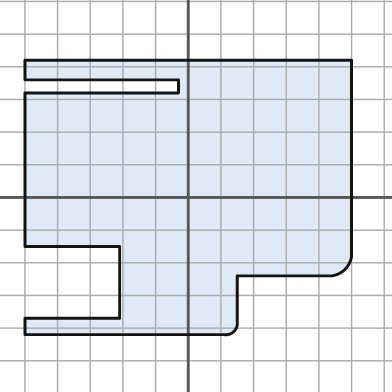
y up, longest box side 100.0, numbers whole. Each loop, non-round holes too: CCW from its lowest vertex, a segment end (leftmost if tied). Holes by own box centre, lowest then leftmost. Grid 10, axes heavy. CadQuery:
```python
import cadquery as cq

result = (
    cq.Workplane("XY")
    .moveTo(-50.0, -42.0)
    .lineTo(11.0, -42.0)
    .threePointArc((14.0, -41.0), (15.0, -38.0))
    .lineTo(15.0, -24.0)
    .lineTo(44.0, -24.0)
    .threePointArc((48.0, -22.0), (50.0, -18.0))
    .lineTo(50.0, 42.0)
    .lineTo(-50.0, 42.0)
    .lineTo(-50.0, 36.0)
    .lineTo(-3.0, 36.0)
    .lineTo(-3.0, 32.0)
    .lineTo(-50.0, 32.0)
    .lineTo(-50.0, -15.0)
    .lineTo(-21.0, -15.0)
    .lineTo(-21.0, -37.0)
    .lineTo(-50.0, -37.0)
    .close()
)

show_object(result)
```